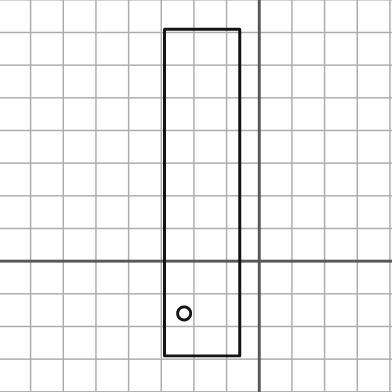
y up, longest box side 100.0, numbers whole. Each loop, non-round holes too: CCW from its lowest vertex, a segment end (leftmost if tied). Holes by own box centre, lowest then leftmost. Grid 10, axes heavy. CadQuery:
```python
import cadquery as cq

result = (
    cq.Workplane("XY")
    .moveTo(-29.0, -29.0)
    .lineTo(-6.0, -29.0)
    .lineTo(-6.0, 71.0)
    .lineTo(-29.0, 71.0)
    .close()
    .moveTo(-23.0, -16.0)
    .circle(2.0)
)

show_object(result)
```